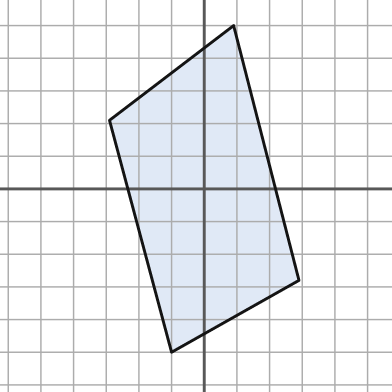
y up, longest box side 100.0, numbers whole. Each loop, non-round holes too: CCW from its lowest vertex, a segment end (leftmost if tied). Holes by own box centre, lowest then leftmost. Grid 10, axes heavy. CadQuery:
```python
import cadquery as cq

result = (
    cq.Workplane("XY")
    .moveTo(-10.0, -50.0)
    .lineTo(29.0, -28.0)
    .lineTo(9.0, 50.0)
    .lineTo(-29.0, 21.0)
    .close()
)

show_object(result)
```